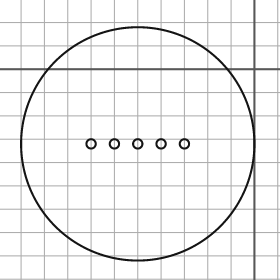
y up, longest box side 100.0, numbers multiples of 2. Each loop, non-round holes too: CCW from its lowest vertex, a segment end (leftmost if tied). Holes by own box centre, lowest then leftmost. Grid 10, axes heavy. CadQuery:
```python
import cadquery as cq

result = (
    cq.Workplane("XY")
    .moveTo(-50.0, -32.0)
    .circle(50.0)
    .moveTo(-70.0, -32.0)
    .circle(2.0)
    .moveTo(-60.0, -32.0)
    .circle(2.0)
    .moveTo(-50.0, -32.0)
    .circle(2.0)
    .moveTo(-40.0, -32.0)
    .circle(2.0)
    .moveTo(-30.0, -32.0)
    .circle(2.0)
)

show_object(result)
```